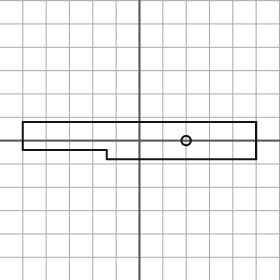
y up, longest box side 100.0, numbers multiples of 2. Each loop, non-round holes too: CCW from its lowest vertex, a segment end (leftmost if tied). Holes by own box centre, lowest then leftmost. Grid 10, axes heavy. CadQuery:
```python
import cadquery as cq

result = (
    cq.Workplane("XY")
    .moveTo(-14.0, -8.0)
    .lineTo(50.0, -8.0)
    .lineTo(50.0, 8.0)
    .lineTo(-50.0, 8.0)
    .lineTo(-50.0, -4.0)
    .lineTo(-14.0, -4.0)
    .close()
    .moveTo(20.0, 0.0)
    .circle(2.0)
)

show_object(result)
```